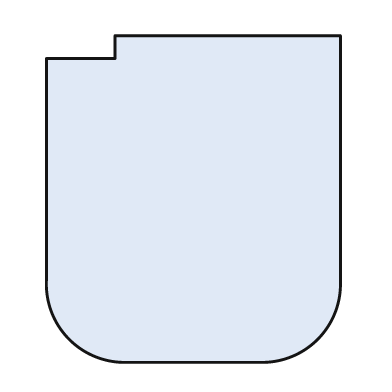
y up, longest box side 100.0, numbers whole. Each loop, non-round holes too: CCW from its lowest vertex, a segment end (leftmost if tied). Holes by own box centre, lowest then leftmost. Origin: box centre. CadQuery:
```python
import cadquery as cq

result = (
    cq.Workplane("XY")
    .moveTo(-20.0, -50.0)
    .lineTo(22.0, -50.0)
    .threePointArc((38.0, -43.0), (45.0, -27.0))
    .lineTo(45.0, 50.0)
    .lineTo(-24.0, 50.0)
    .lineTo(-24.0, 43.0)
    .lineTo(-45.0, 43.0)
    .lineTo(-45.0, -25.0)
    .threePointArc((-38.0, -43.0), (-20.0, -50.0))
    .close()
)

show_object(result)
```